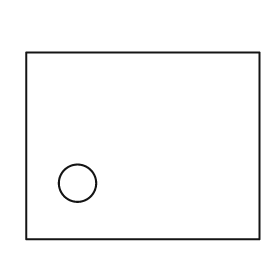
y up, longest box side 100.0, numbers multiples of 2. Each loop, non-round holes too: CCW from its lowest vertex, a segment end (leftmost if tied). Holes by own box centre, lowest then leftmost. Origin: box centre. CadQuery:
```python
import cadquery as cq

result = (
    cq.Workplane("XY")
    .moveTo(-50.0, -40.0)
    .lineTo(50.0, -40.0)
    .lineTo(50.0, 40.0)
    .lineTo(-50.0, 40.0)
    .close()
    .moveTo(-28.0, -16.0)
    .circle(8.0)
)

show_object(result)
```